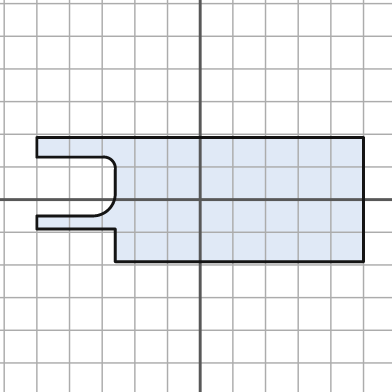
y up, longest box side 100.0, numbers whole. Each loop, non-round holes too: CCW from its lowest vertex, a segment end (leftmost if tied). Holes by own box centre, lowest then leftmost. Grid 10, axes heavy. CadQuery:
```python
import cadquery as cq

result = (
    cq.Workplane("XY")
    .moveTo(-26.0, -19.0)
    .lineTo(50.0, -19.0)
    .lineTo(50.0, 19.0)
    .lineTo(-50.0, 19.0)
    .lineTo(-50.0, 13.0)
    .lineTo(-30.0, 13.0)
    .threePointArc((-27.0, 12.0), (-26.0, 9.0))
    .lineTo(-26.0, 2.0)
    .threePointArc((-28.0, -3.0), (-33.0, -5.0))
    .lineTo(-50.0, -5.0)
    .lineTo(-50.0, -9.0)
    .lineTo(-26.0, -9.0)
    .close()
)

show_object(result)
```